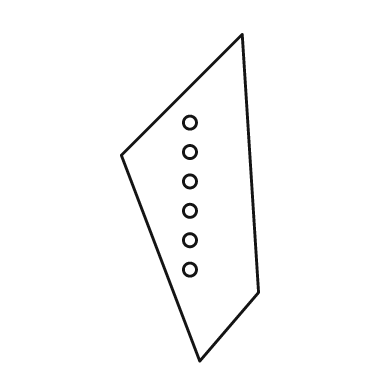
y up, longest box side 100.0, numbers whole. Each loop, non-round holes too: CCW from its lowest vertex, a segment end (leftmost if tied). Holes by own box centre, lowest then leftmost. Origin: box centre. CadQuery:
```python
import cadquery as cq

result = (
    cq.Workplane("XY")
    .moveTo(3.0, -50.0)
    .lineTo(21.0, -29.0)
    .lineTo(16.0, 50.0)
    .lineTo(-21.0, 13.0)
    .close()
    .moveTo(0.0, -22.0)
    .circle(2.0)
    .moveTo(0.0, -13.0)
    .circle(2.0)
    .moveTo(0.0, -4.0)
    .circle(2.0)
    .moveTo(0.0, 5.0)
    .circle(2.0)
    .moveTo(0.0, 14.0)
    .circle(2.0)
    .moveTo(0.0, 23.0)
    .circle(2.0)
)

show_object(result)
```